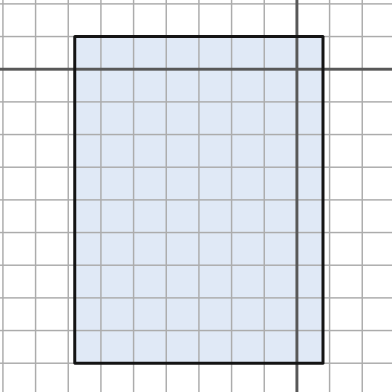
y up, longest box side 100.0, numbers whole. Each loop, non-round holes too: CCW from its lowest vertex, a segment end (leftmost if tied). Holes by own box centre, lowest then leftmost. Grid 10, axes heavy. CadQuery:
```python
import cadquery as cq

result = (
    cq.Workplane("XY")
    .moveTo(-68.0, -90.0)
    .lineTo(8.0, -90.0)
    .lineTo(8.0, 10.0)
    .lineTo(-68.0, 10.0)
    .close()
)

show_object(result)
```